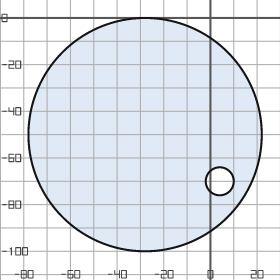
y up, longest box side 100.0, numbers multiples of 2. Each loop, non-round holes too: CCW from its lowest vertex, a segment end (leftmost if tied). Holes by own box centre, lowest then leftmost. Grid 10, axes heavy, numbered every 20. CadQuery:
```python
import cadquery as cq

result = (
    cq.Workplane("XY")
    .moveTo(-28.0, -50.0)
    .circle(50.0)
    .moveTo(4.0, -70.0)
    .circle(6.0)
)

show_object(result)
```